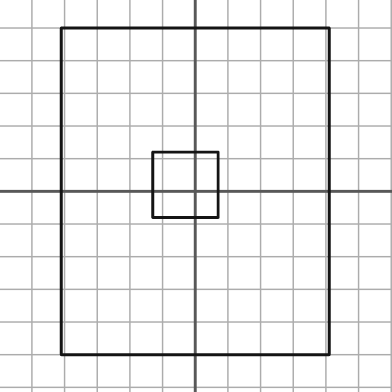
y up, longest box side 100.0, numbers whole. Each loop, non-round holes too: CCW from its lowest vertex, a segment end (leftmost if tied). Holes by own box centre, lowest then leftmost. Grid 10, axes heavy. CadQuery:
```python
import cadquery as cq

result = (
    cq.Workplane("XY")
    .moveTo(-41.0, -50.0)
    .lineTo(41.0, -50.0)
    .lineTo(41.0, 50.0)
    .lineTo(-41.0, 50.0)
    .close()
    .moveTo(-13.0, -8.0)
    .lineTo(7.0, -8.0)
    .lineTo(7.0, 12.0)
    .lineTo(-13.0, 12.0)
    .close()
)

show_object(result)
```